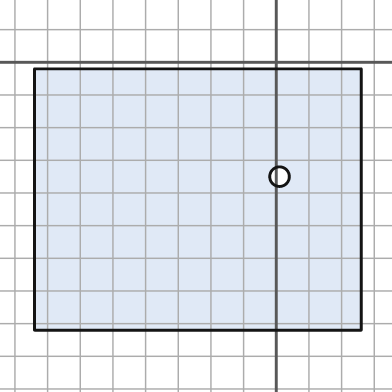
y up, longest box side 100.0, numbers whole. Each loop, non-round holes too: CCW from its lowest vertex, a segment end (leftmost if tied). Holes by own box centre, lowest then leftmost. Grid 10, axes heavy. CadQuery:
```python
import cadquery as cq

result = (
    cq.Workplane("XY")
    .moveTo(-74.0, -82.0)
    .lineTo(26.0, -82.0)
    .lineTo(26.0, -2.0)
    .lineTo(-74.0, -2.0)
    .close()
    .moveTo(1.0, -35.0)
    .circle(3.0)
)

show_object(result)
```